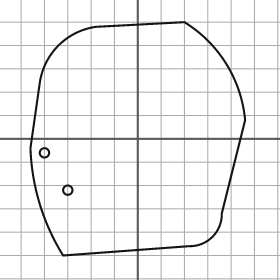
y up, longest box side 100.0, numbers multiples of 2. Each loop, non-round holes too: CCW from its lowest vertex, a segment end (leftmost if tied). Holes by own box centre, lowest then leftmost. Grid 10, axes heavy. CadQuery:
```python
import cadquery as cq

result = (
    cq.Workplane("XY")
    .moveTo(-32.0, -50.0)
    .lineTo(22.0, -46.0)
    .threePointArc((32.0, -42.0), (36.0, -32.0))
    .lineTo(46.0, 8.0)
    .threePointArc((38.0, 32.0), (20.0, 50.0))
    .lineTo(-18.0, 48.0)
    .threePointArc((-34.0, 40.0), (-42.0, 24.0))
    .lineTo(-46.0, -4.0)
    .threePointArc((-42.0, -28.0), (-32.0, -50.0))
    .close()
    .moveTo(-30.0, -22.0)
    .circle(2.0)
    .moveTo(-40.0, -6.0)
    .circle(2.0)
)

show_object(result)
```